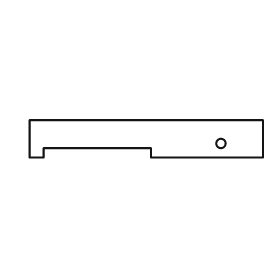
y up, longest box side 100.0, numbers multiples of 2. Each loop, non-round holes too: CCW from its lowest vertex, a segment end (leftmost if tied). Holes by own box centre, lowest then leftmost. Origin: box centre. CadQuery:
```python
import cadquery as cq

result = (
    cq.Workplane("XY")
    .moveTo(-50.0, -8.0)
    .lineTo(-44.0, -8.0)
    .lineTo(-44.0, -4.0)
    .lineTo(2.0, -4.0)
    .lineTo(2.0, -8.0)
    .lineTo(50.0, -8.0)
    .lineTo(50.0, 8.0)
    .lineTo(-50.0, 8.0)
    .close()
    .moveTo(32.0, -2.0)
    .circle(2.0)
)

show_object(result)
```